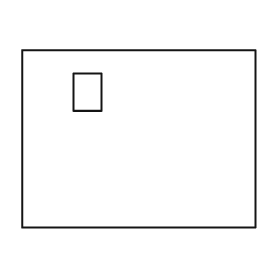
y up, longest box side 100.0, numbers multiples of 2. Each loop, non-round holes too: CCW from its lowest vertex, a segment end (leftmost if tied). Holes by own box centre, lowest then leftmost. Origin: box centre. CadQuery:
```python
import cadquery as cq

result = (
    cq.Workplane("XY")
    .moveTo(-50.0, -38.0)
    .lineTo(50.0, -38.0)
    .lineTo(50.0, 38.0)
    .lineTo(-50.0, 38.0)
    .close()
    .moveTo(-28.0, 12.0)
    .lineTo(-16.0, 12.0)
    .lineTo(-16.0, 28.0)
    .lineTo(-28.0, 28.0)
    .close()
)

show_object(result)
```